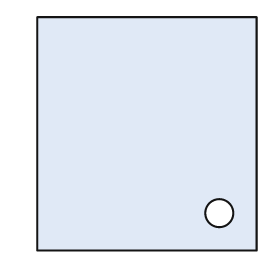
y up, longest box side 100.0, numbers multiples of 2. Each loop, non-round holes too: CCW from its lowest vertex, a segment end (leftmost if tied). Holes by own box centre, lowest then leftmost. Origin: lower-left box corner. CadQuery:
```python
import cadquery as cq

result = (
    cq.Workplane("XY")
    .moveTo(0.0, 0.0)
    .lineTo(94.0, 0.0)
    .lineTo(94.0, 100.0)
    .lineTo(0.0, 100.0)
    .close()
    .moveTo(78.0, 16.0)
    .circle(6.0)
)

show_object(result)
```